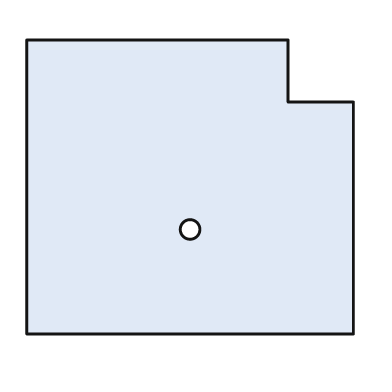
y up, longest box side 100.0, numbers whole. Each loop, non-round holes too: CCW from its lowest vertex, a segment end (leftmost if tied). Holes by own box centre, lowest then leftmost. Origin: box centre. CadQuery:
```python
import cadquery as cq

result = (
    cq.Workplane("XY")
    .moveTo(-50.0, -45.0)
    .lineTo(50.0, -45.0)
    .lineTo(50.0, 26.0)
    .lineTo(30.0, 26.0)
    .lineTo(30.0, 45.0)
    .lineTo(-50.0, 45.0)
    .close()
    .moveTo(0.0, -13.0)
    .circle(3.0)
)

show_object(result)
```